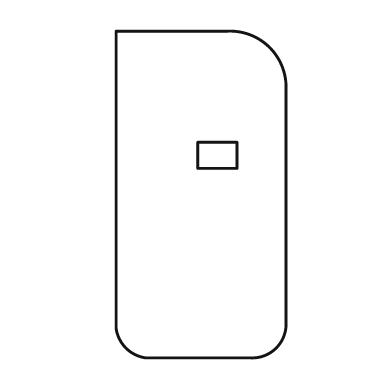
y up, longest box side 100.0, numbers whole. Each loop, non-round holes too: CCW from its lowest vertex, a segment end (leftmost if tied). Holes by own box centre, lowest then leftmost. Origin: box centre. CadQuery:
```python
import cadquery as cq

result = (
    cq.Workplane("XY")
    .moveTo(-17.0, -50.0)
    .lineTo(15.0, -50.0)
    .threePointArc((23.0, -47.0), (26.0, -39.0))
    .lineTo(26.0, 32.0)
    .threePointArc((21.0, 45.0), (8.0, 50.0))
    .lineTo(-26.0, 50.0)
    .lineTo(-26.0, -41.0)
    .threePointArc((-23.0, -47.0), (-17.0, -50.0))
    .close()
    .moveTo(-1.0, 8.0)
    .lineTo(11.0, 8.0)
    .lineTo(11.0, 16.0)
    .lineTo(-1.0, 16.0)
    .close()
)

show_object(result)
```